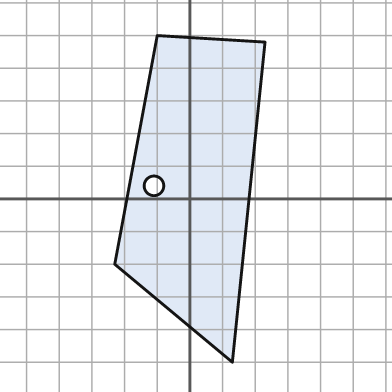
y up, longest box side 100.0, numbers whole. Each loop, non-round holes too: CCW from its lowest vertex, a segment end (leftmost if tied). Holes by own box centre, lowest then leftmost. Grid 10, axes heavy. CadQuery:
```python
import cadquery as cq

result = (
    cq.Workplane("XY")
    .moveTo(13.0, -50.0)
    .lineTo(23.0, 48.0)
    .lineTo(-10.0, 50.0)
    .lineTo(-23.0, -20.0)
    .close()
    .moveTo(-11.0, 4.0)
    .circle(3.0)
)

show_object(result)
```